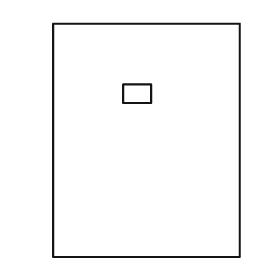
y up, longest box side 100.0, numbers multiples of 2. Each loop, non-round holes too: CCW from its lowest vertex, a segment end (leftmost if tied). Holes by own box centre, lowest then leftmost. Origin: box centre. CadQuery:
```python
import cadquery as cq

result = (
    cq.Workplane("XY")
    .moveTo(-40.0, -50.0)
    .lineTo(40.0, -50.0)
    .lineTo(40.0, 50.0)
    .lineTo(-40.0, 50.0)
    .close()
    .moveTo(-10.0, 16.0)
    .lineTo(2.0, 16.0)
    .lineTo(2.0, 24.0)
    .lineTo(-10.0, 24.0)
    .close()
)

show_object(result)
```